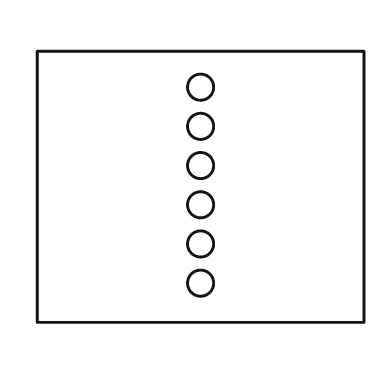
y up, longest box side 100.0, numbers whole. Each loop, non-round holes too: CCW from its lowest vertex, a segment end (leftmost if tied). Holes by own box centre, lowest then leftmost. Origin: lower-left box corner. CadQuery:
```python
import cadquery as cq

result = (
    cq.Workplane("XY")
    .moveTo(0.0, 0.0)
    .lineTo(100.0, 0.0)
    .lineTo(100.0, 83.0)
    .lineTo(0.0, 83.0)
    .close()
    .moveTo(50.0, 12.0)
    .circle(4.0)
    .moveTo(50.0, 24.0)
    .circle(4.0)
    .moveTo(50.0, 36.0)
    .circle(4.0)
    .moveTo(50.0, 48.0)
    .circle(4.0)
    .moveTo(50.0, 60.0)
    .circle(4.0)
    .moveTo(50.0, 72.0)
    .circle(4.0)
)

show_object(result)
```